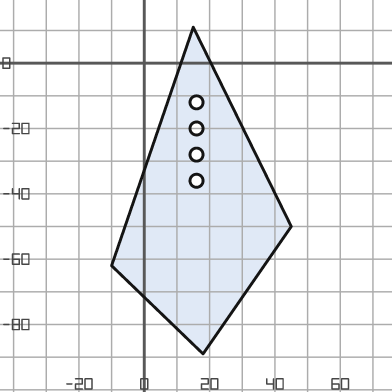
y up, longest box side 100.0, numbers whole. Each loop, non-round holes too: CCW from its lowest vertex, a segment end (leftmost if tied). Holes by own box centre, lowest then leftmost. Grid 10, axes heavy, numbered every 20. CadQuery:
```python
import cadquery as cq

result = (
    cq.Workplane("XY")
    .moveTo(18.0, -89.0)
    .lineTo(45.0, -50.0)
    .lineTo(15.0, 11.0)
    .lineTo(-10.0, -62.0)
    .close()
    .moveTo(16.0, -36.0)
    .circle(2.0)
    .moveTo(16.0, -28.0)
    .circle(2.0)
    .moveTo(16.0, -20.0)
    .circle(2.0)
    .moveTo(16.0, -12.0)
    .circle(2.0)
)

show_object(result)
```